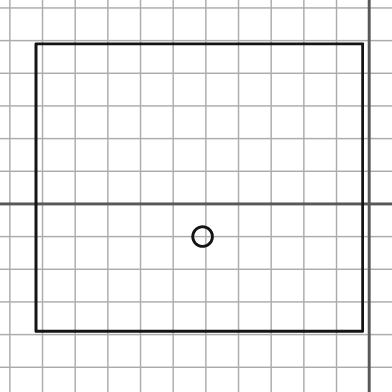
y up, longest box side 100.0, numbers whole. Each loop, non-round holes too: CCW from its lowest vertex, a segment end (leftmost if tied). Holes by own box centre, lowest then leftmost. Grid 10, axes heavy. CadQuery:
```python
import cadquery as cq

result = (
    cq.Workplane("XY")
    .moveTo(-102.0, -39.0)
    .lineTo(-2.0, -39.0)
    .lineTo(-2.0, 49.0)
    .lineTo(-102.0, 49.0)
    .close()
    .moveTo(-51.0, -10.0)
    .circle(3.0)
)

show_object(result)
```